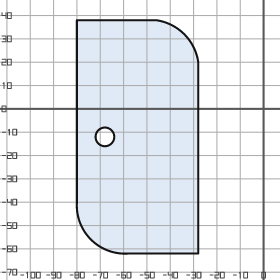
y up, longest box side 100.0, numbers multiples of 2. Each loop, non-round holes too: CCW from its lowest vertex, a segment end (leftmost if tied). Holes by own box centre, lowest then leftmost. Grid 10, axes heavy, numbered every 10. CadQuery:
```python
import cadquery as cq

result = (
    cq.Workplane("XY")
    .moveTo(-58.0, -62.0)
    .lineTo(-28.0, -62.0)
    .lineTo(-28.0, 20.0)
    .threePointArc((-34.0, 32.0), (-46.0, 38.0))
    .lineTo(-80.0, 38.0)
    .lineTo(-80.0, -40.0)
    .threePointArc((-74.0, -56.0), (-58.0, -62.0))
    .close()
    .moveTo(-68.0, -12.0)
    .circle(4.0)
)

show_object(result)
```